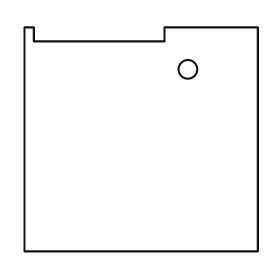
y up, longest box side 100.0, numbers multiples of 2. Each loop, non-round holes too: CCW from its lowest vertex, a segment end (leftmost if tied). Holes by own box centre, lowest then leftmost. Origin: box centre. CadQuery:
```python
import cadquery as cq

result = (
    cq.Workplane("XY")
    .moveTo(-50.0, -48.0)
    .lineTo(50.0, -48.0)
    .lineTo(50.0, 48.0)
    .lineTo(10.0, 48.0)
    .lineTo(10.0, 42.0)
    .lineTo(-46.0, 42.0)
    .lineTo(-46.0, 48.0)
    .lineTo(-50.0, 48.0)
    .close()
    .moveTo(20.0, 30.0)
    .circle(4.0)
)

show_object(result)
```